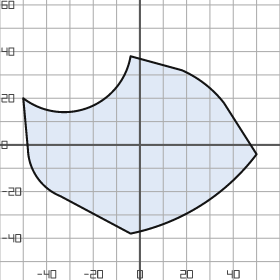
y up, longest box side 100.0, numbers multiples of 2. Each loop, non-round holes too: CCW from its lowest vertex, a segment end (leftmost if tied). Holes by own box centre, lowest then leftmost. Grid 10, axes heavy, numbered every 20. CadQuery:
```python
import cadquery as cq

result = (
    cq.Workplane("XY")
    .moveTo(-4.0, -38.0)
    .threePointArc((26.0, -26.0), (50.0, -4.0))
    .lineTo(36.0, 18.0)
    .threePointArc((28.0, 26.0), (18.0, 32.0))
    .lineTo(-4.0, 38.0)
    .threePointArc((-22.0, 16.0), (-50.0, 20.0))
    .lineTo(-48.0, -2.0)
    .threePointArc((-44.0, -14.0), (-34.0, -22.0))
    .close()
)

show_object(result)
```